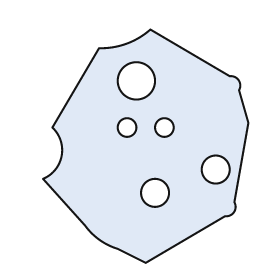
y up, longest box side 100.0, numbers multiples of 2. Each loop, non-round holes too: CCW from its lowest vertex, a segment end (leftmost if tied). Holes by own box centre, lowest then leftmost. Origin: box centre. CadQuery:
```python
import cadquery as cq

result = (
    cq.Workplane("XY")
    .moveTo(0.0, -50.0)
    .lineTo(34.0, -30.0)
    .threePointArc((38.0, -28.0), (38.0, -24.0))
    .lineTo(44.0, 10.0)
    .lineTo(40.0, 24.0)
    .threePointArc((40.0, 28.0), (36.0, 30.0))
    .lineTo(2.0, 50.0)
    .threePointArc((-8.0, 44.0), (-20.0, 42.0))
    .lineTo(-40.0, 8.0)
    .threePointArc((-36.0, -4.0), (-44.0, -14.0))
    .lineTo(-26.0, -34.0)
    .threePointArc((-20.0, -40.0), (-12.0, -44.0))
    .close()
    .moveTo(4.0, -20.0)
    .circle(6.0)
    .moveTo(30.0, -10.0)
    .circle(6.0)
    .moveTo(-8.0, 8.0)
    .circle(4.0)
    .moveTo(8.0, 8.0)
    .circle(4.0)
    .moveTo(-4.0, 28.0)
    .circle(8.0)
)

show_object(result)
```